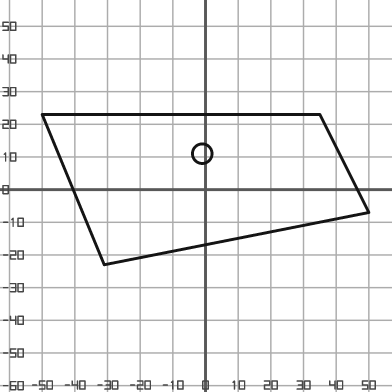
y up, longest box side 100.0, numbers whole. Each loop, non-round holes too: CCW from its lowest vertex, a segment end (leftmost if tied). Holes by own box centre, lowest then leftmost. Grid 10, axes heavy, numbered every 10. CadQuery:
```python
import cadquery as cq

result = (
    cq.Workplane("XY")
    .moveTo(-31.0, -23.0)
    .lineTo(50.0, -7.0)
    .lineTo(35.0, 23.0)
    .lineTo(-50.0, 23.0)
    .close()
    .moveTo(-1.0, 11.0)
    .circle(3.0)
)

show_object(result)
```